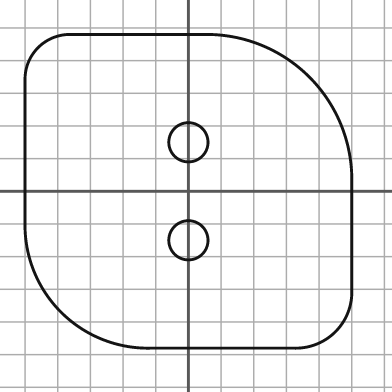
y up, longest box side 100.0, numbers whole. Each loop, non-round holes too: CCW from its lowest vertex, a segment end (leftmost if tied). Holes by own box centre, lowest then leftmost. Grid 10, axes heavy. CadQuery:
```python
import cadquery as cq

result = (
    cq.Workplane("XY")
    .moveTo(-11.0, -48.0)
    .lineTo(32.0, -48.0)
    .threePointArc((45.0, -43.0), (50.0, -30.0))
    .lineTo(50.0, 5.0)
    .threePointArc((37.0, 35.0), (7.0, 48.0))
    .lineTo(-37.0, 48.0)
    .threePointArc((-46.0, 44.0), (-50.0, 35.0))
    .lineTo(-50.0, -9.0)
    .threePointArc((-39.0, -37.0), (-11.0, -48.0))
    .close()
    .moveTo(0.0, -15.0)
    .circle(6.0)
    .moveTo(0.0, 15.0)
    .circle(6.0)
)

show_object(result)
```